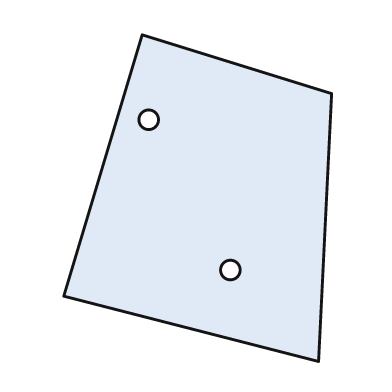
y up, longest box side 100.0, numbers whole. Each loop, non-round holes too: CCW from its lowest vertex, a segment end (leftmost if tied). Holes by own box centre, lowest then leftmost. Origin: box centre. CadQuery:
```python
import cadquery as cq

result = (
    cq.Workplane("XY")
    .moveTo(37.0, -50.0)
    .lineTo(41.0, 32.0)
    .lineTo(-17.0, 50.0)
    .lineTo(-41.0, -30.0)
    .close()
    .moveTo(10.0, -22.0)
    .circle(3.0)
    .moveTo(-15.0, 24.0)
    .circle(3.0)
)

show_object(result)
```